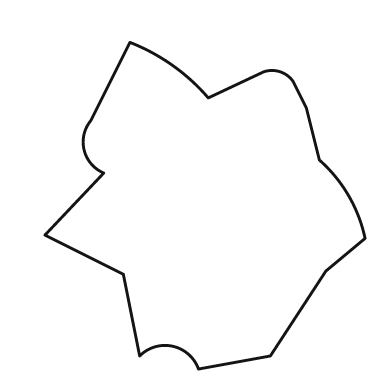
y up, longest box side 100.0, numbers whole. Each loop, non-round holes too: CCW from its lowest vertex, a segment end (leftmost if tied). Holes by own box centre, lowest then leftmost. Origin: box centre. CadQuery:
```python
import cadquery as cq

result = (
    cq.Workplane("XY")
    .moveTo(-2.0, -50.0)
    .lineTo(20.0, -46.0)
    .lineTo(37.0, -20.0)
    .lineTo(49.0, -10.0)
    .threePointArc((44.0, 3.0), (35.0, 14.0))
    .lineTo(31.0, 30.0)
    .lineTo(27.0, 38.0)
    .threePointArc((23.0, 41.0), (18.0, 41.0))
    .lineTo(1.0, 33.0)
    .threePointArc((-10.0, 43.0), (-23.0, 50.0))
    .lineTo(-35.0, 26.0)
    .threePointArc((-37.0, 17.0), (-31.0, 10.0))
    .lineTo(-49.0, -9.0)
    .lineTo(-25.0, -21.0)
    .lineTo(-20.0, -46.0)
    .threePointArc((-10.0, -43.0), (-2.0, -50.0))
    .close()
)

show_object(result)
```